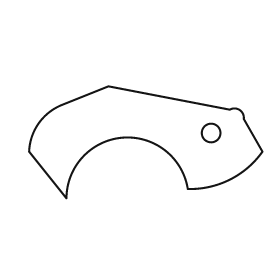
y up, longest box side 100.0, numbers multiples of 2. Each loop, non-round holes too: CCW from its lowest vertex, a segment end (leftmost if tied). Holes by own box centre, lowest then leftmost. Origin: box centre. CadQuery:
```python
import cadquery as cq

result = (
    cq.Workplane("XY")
    .moveTo(-34.0, -24.0)
    .threePointArc((-10.0, 2.0), (18.0, -20.0))
    .threePointArc((36.0, -16.0), (50.0, -4.0))
    .lineTo(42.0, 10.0)
    .threePointArc((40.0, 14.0), (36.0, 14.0))
    .lineTo(-16.0, 24.0)
    .lineTo(-36.0, 16.0)
    .threePointArc((-46.0, 8.0), (-50.0, -4.0))
    .close()
    .moveTo(28.0, 4.0)
    .circle(4.0)
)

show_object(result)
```